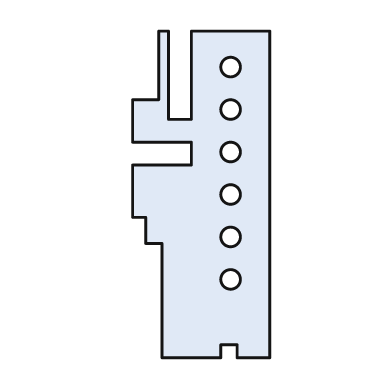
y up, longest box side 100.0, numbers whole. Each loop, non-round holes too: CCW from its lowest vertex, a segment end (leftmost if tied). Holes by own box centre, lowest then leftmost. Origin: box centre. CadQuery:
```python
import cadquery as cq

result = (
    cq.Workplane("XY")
    .moveTo(-12.0, -50.0)
    .lineTo(6.0, -50.0)
    .lineTo(6.0, -46.0)
    .lineTo(11.0, -46.0)
    .lineTo(11.0, -50.0)
    .lineTo(21.0, -50.0)
    .lineTo(21.0, 50.0)
    .lineTo(-3.0, 50.0)
    .lineTo(-3.0, 23.0)
    .lineTo(-10.0, 23.0)
    .lineTo(-10.0, 50.0)
    .lineTo(-13.0, 50.0)
    .lineTo(-13.0, 29.0)
    .lineTo(-21.0, 29.0)
    .lineTo(-21.0, 16.0)
    .lineTo(-3.0, 16.0)
    .lineTo(-3.0, 9.0)
    .lineTo(-21.0, 9.0)
    .lineTo(-21.0, -7.0)
    .lineTo(-17.0, -7.0)
    .lineTo(-17.0, -15.0)
    .lineTo(-12.0, -15.0)
    .close()
    .moveTo(9.0, -26.0)
    .circle(3.0)
    .moveTo(9.0, -13.0)
    .circle(3.0)
    .moveTo(9.0, 0.0)
    .circle(3.0)
    .moveTo(9.0, 13.0)
    .circle(3.0)
    .moveTo(9.0, 26.0)
    .circle(3.0)
    .moveTo(9.0, 39.0)
    .circle(3.0)
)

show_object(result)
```